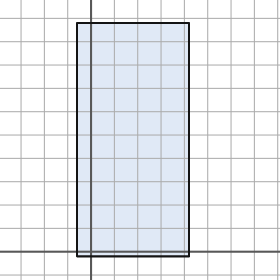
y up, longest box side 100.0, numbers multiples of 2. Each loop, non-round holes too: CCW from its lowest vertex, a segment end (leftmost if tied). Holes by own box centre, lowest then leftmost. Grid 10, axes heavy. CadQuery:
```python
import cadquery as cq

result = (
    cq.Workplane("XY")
    .moveTo(-6.0, -2.0)
    .lineTo(42.0, -2.0)
    .lineTo(42.0, 98.0)
    .lineTo(-6.0, 98.0)
    .close()
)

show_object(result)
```